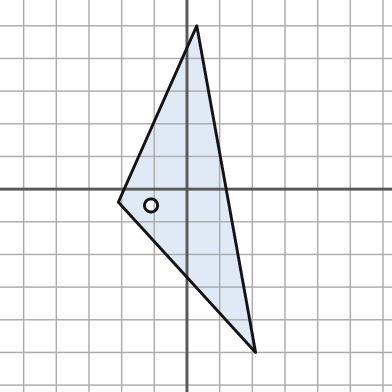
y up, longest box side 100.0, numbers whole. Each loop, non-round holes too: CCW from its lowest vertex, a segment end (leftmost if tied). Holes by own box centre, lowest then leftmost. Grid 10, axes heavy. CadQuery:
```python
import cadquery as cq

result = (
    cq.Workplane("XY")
    .moveTo(21.0, -50.0)
    .lineTo(3.0, 50.0)
    .lineTo(-21.0, -4.0)
    .close()
    .moveTo(-11.0, -5.0)
    .circle(2.0)
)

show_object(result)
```